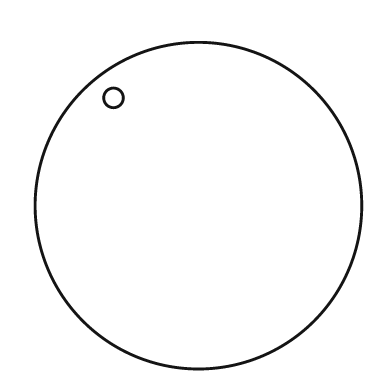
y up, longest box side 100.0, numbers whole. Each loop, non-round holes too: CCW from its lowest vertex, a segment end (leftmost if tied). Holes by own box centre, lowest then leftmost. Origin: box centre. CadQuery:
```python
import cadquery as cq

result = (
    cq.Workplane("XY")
    .moveTo(0.0, 0.0)
    .circle(50.0)
    .moveTo(-26.0, 33.0)
    .circle(3.0)
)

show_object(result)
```